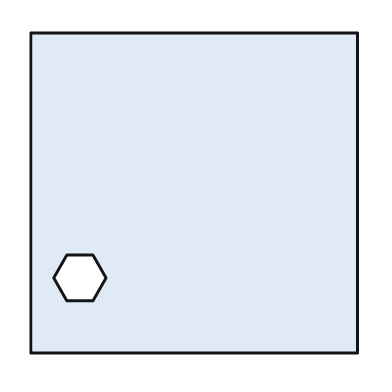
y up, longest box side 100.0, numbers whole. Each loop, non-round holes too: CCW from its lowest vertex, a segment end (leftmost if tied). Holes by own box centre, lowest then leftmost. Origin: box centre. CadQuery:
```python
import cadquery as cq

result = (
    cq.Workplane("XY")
    .moveTo(-50.0, -49.0)
    .lineTo(50.0, -49.0)
    .lineTo(50.0, 49.0)
    .lineTo(-50.0, 49.0)
    .close()
    .moveTo(-39.0, -33.0)
    .lineTo(-31.0, -33.0)
    .lineTo(-27.0, -26.0)
    .lineTo(-31.0, -19.0)
    .lineTo(-39.0, -19.0)
    .lineTo(-43.0, -26.0)
    .close()
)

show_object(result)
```